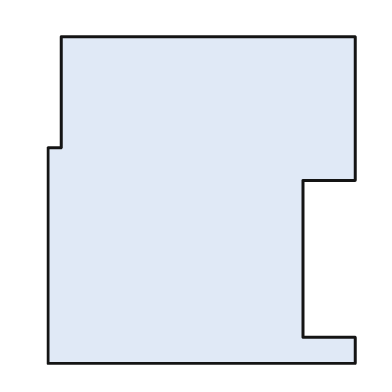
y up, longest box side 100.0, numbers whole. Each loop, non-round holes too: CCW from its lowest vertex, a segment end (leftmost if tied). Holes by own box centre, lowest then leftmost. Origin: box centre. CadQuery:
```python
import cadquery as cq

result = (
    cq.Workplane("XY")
    .moveTo(-47.0, -50.0)
    .lineTo(47.0, -50.0)
    .lineTo(47.0, -42.0)
    .lineTo(31.0, -42.0)
    .lineTo(31.0, 6.0)
    .lineTo(47.0, 6.0)
    .lineTo(47.0, 50.0)
    .lineTo(-43.0, 50.0)
    .lineTo(-43.0, 16.0)
    .lineTo(-47.0, 16.0)
    .close()
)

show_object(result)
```